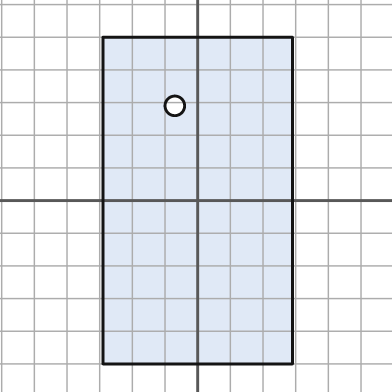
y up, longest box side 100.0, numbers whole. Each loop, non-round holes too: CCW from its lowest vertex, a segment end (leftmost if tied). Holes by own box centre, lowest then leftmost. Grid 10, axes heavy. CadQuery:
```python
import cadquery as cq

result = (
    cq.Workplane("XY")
    .moveTo(-29.0, -50.0)
    .lineTo(29.0, -50.0)
    .lineTo(29.0, 50.0)
    .lineTo(-29.0, 50.0)
    .close()
    .moveTo(-7.0, 29.0)
    .circle(3.0)
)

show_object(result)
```